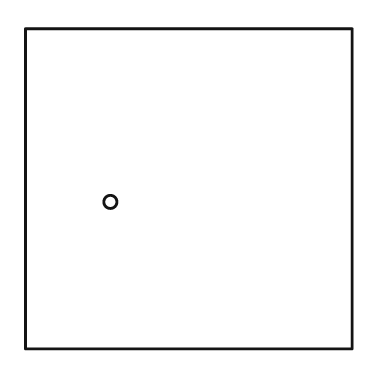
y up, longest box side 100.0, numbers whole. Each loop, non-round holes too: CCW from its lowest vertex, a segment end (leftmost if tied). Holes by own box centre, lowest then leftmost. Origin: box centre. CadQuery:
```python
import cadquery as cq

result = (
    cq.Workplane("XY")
    .moveTo(-50.0, -49.0)
    .lineTo(50.0, -49.0)
    .lineTo(50.0, 49.0)
    .lineTo(-50.0, 49.0)
    .close()
    .moveTo(-24.0, -4.0)
    .circle(2.0)
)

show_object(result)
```